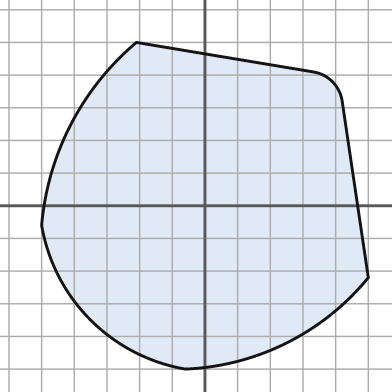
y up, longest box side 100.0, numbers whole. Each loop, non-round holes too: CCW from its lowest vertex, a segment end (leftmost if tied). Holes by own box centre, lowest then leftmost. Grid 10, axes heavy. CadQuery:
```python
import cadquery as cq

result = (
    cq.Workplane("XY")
    .moveTo(-6.0, -50.0)
    .threePointArc((25.0, -42.0), (50.0, -22.0))
    .lineTo(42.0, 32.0)
    .threePointArc((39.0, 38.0), (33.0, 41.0))
    .lineTo(-21.0, 50.0)
    .threePointArc((-41.0, 25.0), (-50.0, -6.0))
    .threePointArc((-35.0, -35.0), (-6.0, -50.0))
    .close()
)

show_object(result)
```